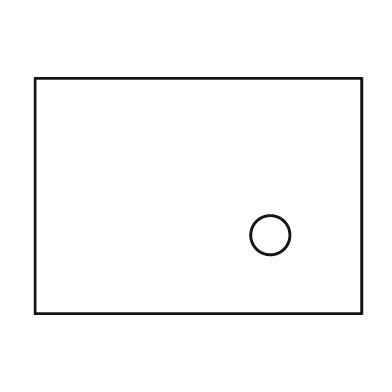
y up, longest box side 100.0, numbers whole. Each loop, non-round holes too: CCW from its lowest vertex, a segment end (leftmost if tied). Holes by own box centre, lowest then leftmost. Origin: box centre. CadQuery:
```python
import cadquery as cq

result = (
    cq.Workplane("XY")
    .moveTo(-50.0, -36.0)
    .lineTo(50.0, -36.0)
    .lineTo(50.0, 36.0)
    .lineTo(-50.0, 36.0)
    .close()
    .moveTo(22.0, -12.0)
    .circle(6.0)
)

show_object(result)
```